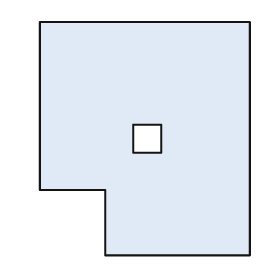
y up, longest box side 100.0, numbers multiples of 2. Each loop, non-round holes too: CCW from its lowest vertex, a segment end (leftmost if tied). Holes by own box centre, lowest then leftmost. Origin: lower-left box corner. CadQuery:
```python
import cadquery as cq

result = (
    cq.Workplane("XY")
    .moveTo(28.0, 0.0)
    .lineTo(90.0, 0.0)
    .lineTo(90.0, 100.0)
    .lineTo(0.0, 100.0)
    .lineTo(0.0, 28.0)
    .lineTo(28.0, 28.0)
    .close()
    .moveTo(40.0, 44.0)
    .lineTo(52.0, 44.0)
    .lineTo(52.0, 56.0)
    .lineTo(40.0, 56.0)
    .close()
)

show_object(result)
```